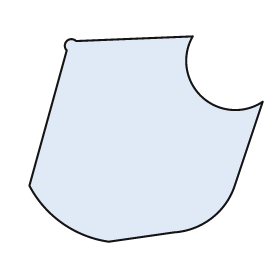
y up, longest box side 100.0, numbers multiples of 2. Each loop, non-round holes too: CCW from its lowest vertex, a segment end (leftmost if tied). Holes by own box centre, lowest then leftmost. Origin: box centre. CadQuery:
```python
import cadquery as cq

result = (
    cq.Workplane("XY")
    .moveTo(-16.0, -44.0)
    .lineTo(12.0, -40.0)
    .threePointArc((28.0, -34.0), (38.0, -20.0))
    .lineTo(50.0, 16.0)
    .threePointArc((24.0, 18.0), (20.0, 44.0))
    .lineTo(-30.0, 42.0)
    .threePointArc((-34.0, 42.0), (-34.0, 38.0))
    .lineTo(-50.0, -20.0)
    .threePointArc((-36.0, -36.0), (-16.0, -44.0))
    .close()
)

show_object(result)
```